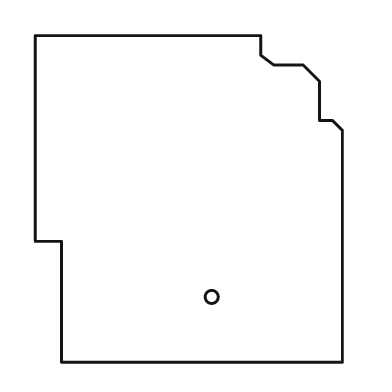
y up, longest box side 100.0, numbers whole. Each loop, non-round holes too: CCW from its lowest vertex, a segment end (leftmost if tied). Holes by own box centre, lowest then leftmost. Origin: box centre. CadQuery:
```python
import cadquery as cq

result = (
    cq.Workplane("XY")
    .moveTo(-39.0, -50.0)
    .lineTo(47.0, -50.0)
    .lineTo(47.0, 21.0)
    .lineTo(44.0, 24.0)
    .lineTo(40.0, 24.0)
    .lineTo(40.0, 36.0)
    .lineTo(35.0, 41.0)
    .lineTo(26.0, 41.0)
    .lineTo(22.0, 44.0)
    .lineTo(22.0, 50.0)
    .lineTo(-47.0, 50.0)
    .lineTo(-47.0, -13.0)
    .lineTo(-39.0, -13.0)
    .close()
    .moveTo(7.0, -30.0)
    .circle(2.0)
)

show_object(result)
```